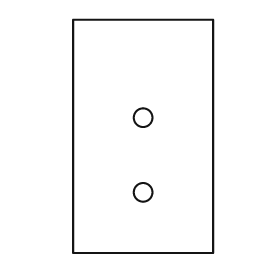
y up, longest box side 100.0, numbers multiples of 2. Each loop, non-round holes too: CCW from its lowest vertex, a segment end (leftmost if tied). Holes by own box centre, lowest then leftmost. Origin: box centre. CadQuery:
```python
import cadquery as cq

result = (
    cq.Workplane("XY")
    .moveTo(-30.0, -50.0)
    .lineTo(30.0, -50.0)
    .lineTo(30.0, 50.0)
    .lineTo(-30.0, 50.0)
    .close()
    .moveTo(0.0, -24.0)
    .circle(4.0)
    .moveTo(0.0, 8.0)
    .circle(4.0)
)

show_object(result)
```